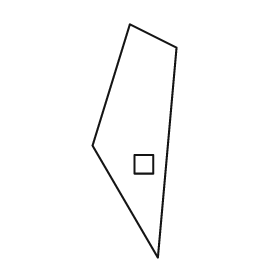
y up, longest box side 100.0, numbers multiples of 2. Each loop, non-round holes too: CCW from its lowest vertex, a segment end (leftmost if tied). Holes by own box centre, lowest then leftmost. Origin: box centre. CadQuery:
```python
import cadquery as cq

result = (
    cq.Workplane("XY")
    .moveTo(10.0, -50.0)
    .lineTo(18.0, 40.0)
    .lineTo(-2.0, 50.0)
    .lineTo(-18.0, -2.0)
    .close()
    .moveTo(0.0, -14.0)
    .lineTo(8.0, -14.0)
    .lineTo(8.0, -6.0)
    .lineTo(0.0, -6.0)
    .close()
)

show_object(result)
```